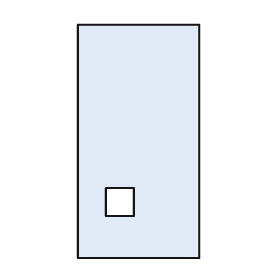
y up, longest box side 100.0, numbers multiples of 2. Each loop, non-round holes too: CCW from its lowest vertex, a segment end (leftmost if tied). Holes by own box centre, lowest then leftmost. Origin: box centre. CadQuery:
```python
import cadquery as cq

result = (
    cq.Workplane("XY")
    .moveTo(-26.0, -50.0)
    .lineTo(26.0, -50.0)
    .lineTo(26.0, 50.0)
    .lineTo(-26.0, 50.0)
    .close()
    .moveTo(-14.0, -32.0)
    .lineTo(-2.0, -32.0)
    .lineTo(-2.0, -20.0)
    .lineTo(-14.0, -20.0)
    .close()
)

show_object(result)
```